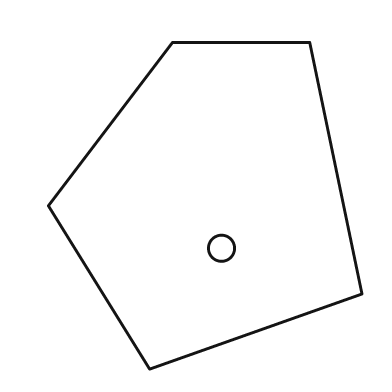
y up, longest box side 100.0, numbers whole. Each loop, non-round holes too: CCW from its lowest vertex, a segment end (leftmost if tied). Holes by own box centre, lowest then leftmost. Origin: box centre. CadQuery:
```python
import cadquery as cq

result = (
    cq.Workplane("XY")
    .moveTo(-17.0, -50.0)
    .lineTo(48.0, -27.0)
    .lineTo(32.0, 50.0)
    .lineTo(-10.0, 50.0)
    .lineTo(-48.0, 0.0)
    .close()
    .moveTo(5.0, -13.0)
    .circle(4.0)
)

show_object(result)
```